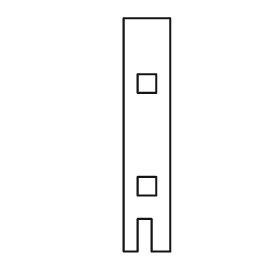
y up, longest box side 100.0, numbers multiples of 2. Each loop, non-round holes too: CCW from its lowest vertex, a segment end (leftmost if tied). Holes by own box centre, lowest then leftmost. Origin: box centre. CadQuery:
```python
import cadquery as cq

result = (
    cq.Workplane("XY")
    .moveTo(-10.0, -50.0)
    .lineTo(-4.0, -50.0)
    .lineTo(-4.0, -36.0)
    .lineTo(2.0, -36.0)
    .lineTo(2.0, -50.0)
    .lineTo(10.0, -50.0)
    .lineTo(10.0, 50.0)
    .lineTo(-10.0, 50.0)
    .close()
    .moveTo(-4.0, -26.0)
    .lineTo(4.0, -26.0)
    .lineTo(4.0, -18.0)
    .lineTo(-4.0, -18.0)
    .close()
    .moveTo(-4.0, 18.0)
    .lineTo(4.0, 18.0)
    .lineTo(4.0, 26.0)
    .lineTo(-4.0, 26.0)
    .close()
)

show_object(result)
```